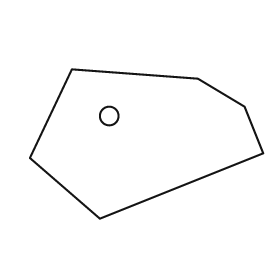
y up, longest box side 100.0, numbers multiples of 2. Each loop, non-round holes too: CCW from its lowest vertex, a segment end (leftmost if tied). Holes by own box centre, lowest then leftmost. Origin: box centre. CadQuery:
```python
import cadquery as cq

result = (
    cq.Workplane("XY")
    .moveTo(-20.0, -32.0)
    .lineTo(50.0, -4.0)
    .lineTo(42.0, 16.0)
    .lineTo(22.0, 28.0)
    .lineTo(-32.0, 32.0)
    .lineTo(-50.0, -6.0)
    .close()
    .moveTo(-16.0, 12.0)
    .circle(4.0)
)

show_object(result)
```